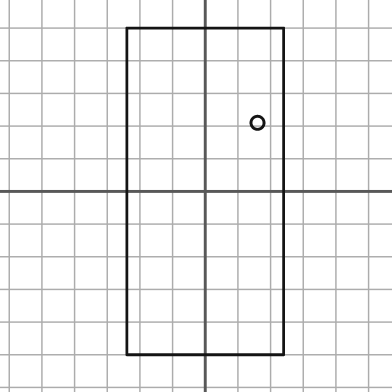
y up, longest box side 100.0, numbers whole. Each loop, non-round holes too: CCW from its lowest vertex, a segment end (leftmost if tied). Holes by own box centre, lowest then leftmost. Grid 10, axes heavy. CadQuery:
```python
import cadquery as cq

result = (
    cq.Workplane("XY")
    .moveTo(-24.0, -50.0)
    .lineTo(24.0, -50.0)
    .lineTo(24.0, 50.0)
    .lineTo(-24.0, 50.0)
    .close()
    .moveTo(16.0, 21.0)
    .circle(2.0)
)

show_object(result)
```